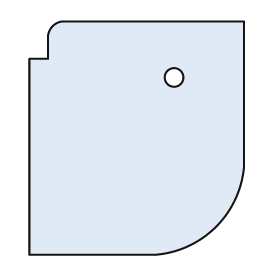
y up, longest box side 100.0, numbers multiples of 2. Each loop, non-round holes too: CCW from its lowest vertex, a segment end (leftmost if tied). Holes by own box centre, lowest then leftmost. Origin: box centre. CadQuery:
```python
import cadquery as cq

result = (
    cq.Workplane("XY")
    .moveTo(-46.0, -50.0)
    .lineTo(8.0, -50.0)
    .threePointArc((34.0, -38.0), (46.0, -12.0))
    .lineTo(46.0, 50.0)
    .lineTo(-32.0, 50.0)
    .threePointArc((-36.0, 48.0), (-38.0, 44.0))
    .lineTo(-38.0, 34.0)
    .lineTo(-46.0, 34.0)
    .close()
    .moveTo(16.0, 26.0)
    .circle(4.0)
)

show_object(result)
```